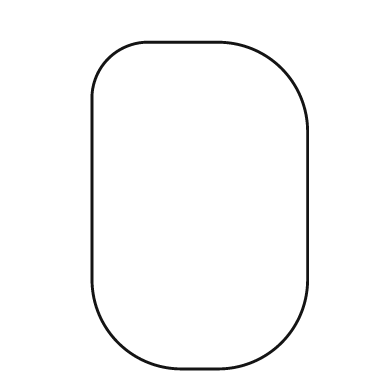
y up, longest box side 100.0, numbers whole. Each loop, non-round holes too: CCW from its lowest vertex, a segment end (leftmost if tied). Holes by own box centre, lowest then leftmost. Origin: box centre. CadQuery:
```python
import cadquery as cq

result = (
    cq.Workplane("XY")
    .moveTo(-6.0, -50.0)
    .lineTo(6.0, -50.0)
    .threePointArc((25.0, -42.0), (33.0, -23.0))
    .lineTo(33.0, 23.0)
    .threePointArc((25.0, 42.0), (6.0, 50.0))
    .lineTo(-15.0, 50.0)
    .threePointArc((-28.0, 45.0), (-33.0, 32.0))
    .lineTo(-33.0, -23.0)
    .threePointArc((-25.0, -42.0), (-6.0, -50.0))
    .close()
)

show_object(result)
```